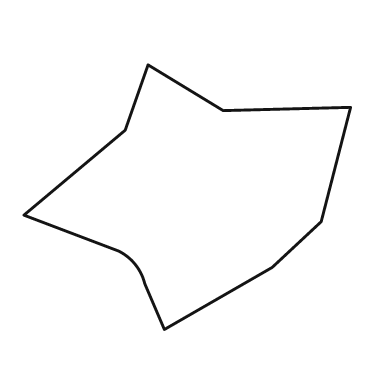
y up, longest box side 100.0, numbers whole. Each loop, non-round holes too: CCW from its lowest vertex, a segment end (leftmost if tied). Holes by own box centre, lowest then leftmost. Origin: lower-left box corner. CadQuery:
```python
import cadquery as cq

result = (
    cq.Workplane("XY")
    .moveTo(43.0, 0.0)
    .lineTo(76.0, 19.0)
    .lineTo(91.0, 33.0)
    .lineTo(100.0, 68.0)
    .lineTo(61.0, 67.0)
    .lineTo(38.0, 81.0)
    .lineTo(31.0, 61.0)
    .lineTo(0.0, 35.0)
    .lineTo(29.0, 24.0)
    .threePointArc((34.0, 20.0), (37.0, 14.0))
    .close()
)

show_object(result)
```